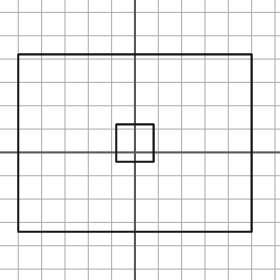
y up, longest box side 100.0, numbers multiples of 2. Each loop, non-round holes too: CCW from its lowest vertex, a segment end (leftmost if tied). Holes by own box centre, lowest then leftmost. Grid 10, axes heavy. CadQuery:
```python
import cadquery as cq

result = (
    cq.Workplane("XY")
    .moveTo(-50.0, -34.0)
    .lineTo(50.0, -34.0)
    .lineTo(50.0, 42.0)
    .lineTo(-50.0, 42.0)
    .close()
    .moveTo(-8.0, -4.0)
    .lineTo(8.0, -4.0)
    .lineTo(8.0, 12.0)
    .lineTo(-8.0, 12.0)
    .close()
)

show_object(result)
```